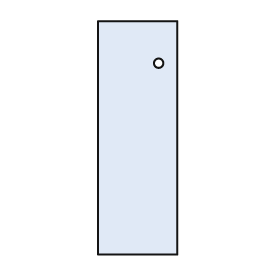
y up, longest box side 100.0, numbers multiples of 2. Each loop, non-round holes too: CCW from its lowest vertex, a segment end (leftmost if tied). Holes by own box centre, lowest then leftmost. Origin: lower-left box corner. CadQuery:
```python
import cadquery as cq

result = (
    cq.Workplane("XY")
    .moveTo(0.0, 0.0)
    .lineTo(34.0, 0.0)
    .lineTo(34.0, 100.0)
    .lineTo(0.0, 100.0)
    .close()
    .moveTo(26.0, 82.0)
    .circle(2.0)
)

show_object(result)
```